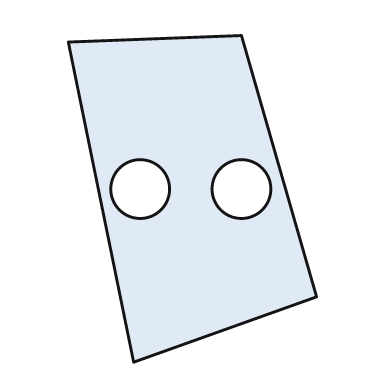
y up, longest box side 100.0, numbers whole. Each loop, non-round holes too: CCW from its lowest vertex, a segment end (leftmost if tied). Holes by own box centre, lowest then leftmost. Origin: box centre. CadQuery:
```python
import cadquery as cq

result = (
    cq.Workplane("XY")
    .moveTo(-18.0, -50.0)
    .lineTo(38.0, -30.0)
    .lineTo(15.0, 50.0)
    .lineTo(-38.0, 48.0)
    .close()
    .moveTo(-16.0, 3.0)
    .circle(9.0)
    .moveTo(15.0, 3.0)
    .circle(9.0)
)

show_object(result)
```